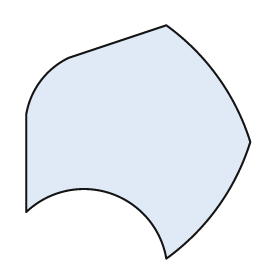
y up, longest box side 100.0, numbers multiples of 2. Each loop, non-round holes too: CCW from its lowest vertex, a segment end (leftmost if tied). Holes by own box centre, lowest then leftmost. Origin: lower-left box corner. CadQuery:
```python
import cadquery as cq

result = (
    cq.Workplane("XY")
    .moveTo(60.0, 0.0)
    .threePointArc((82.0, 22.0), (96.0, 50.0))
    .threePointArc((82.0, 78.0), (60.0, 100.0))
    .lineTo(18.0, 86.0)
    .threePointArc((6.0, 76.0), (0.0, 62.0))
    .lineTo(0.0, 20.0)
    .threePointArc((36.0, 28.0), (60.0, 0.0))
    .close()
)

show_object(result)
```